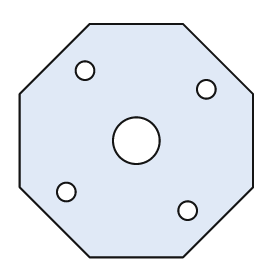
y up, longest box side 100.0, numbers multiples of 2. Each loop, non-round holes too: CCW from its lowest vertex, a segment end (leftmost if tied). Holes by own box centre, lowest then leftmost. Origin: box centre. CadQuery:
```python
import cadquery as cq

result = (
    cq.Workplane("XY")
    .moveTo(-20.0, -50.0)
    .lineTo(20.0, -50.0)
    .lineTo(50.0, -20.0)
    .lineTo(50.0, 20.0)
    .lineTo(20.0, 50.0)
    .lineTo(-20.0, 50.0)
    .lineTo(-50.0, 20.0)
    .lineTo(-50.0, -20.0)
    .close()
    .moveTo(22.0, -30.0)
    .circle(4.0)
    .moveTo(-30.0, -22.0)
    .circle(4.0)
    .moveTo(0.0, 0.0)
    .circle(10.0)
    .moveTo(30.0, 22.0)
    .circle(4.0)
    .moveTo(-22.0, 30.0)
    .circle(4.0)
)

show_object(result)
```